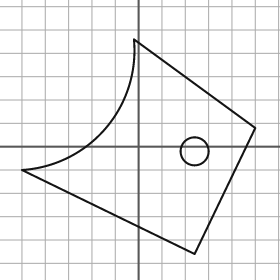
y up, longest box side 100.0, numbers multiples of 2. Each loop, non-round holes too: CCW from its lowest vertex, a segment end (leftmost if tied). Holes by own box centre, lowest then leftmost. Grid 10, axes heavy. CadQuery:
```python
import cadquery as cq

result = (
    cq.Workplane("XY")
    .moveTo(24.0, -46.0)
    .lineTo(50.0, 8.0)
    .lineTo(-2.0, 46.0)
    .threePointArc((-14.0, 8.0), (-50.0, -10.0))
    .close()
    .moveTo(24.0, -2.0)
    .circle(6.0)
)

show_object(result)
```